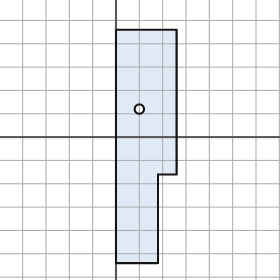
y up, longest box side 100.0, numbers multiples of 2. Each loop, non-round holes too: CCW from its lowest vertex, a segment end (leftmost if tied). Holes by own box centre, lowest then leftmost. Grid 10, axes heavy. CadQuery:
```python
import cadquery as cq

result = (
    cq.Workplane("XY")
    .moveTo(0.0, -54.0)
    .lineTo(18.0, -54.0)
    .lineTo(18.0, -16.0)
    .lineTo(26.0, -16.0)
    .lineTo(26.0, 46.0)
    .lineTo(0.0, 46.0)
    .close()
    .moveTo(10.0, 12.0)
    .circle(2.0)
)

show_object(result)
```